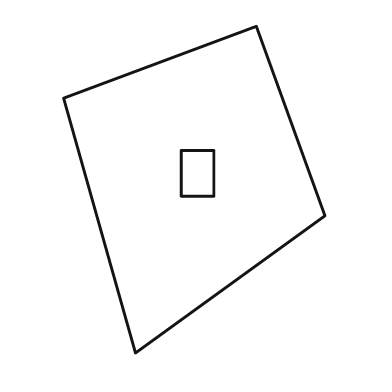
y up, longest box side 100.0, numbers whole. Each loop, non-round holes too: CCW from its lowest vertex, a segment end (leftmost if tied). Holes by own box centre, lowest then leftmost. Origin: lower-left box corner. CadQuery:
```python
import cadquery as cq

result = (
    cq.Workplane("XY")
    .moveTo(22.0, 0.0)
    .lineTo(80.0, 42.0)
    .lineTo(59.0, 100.0)
    .lineTo(0.0, 78.0)
    .close()
    .moveTo(36.0, 48.0)
    .lineTo(46.0, 48.0)
    .lineTo(46.0, 62.0)
    .lineTo(36.0, 62.0)
    .close()
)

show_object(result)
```